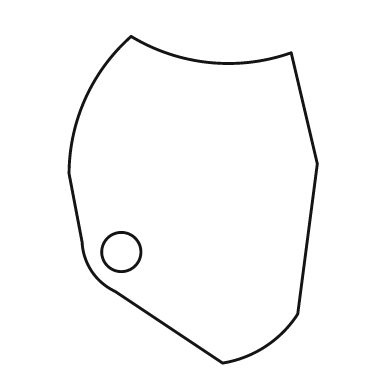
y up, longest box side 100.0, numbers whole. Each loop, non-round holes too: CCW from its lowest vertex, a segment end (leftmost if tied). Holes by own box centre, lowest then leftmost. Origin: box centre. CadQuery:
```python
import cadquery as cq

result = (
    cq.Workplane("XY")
    .moveTo(9.0, -50.0)
    .threePointArc((22.0, -45.0), (32.0, -35.0))
    .lineTo(38.0, 11.0)
    .lineTo(30.0, 45.0)
    .threePointArc((5.0, 42.0), (-19.0, 50.0))
    .threePointArc((-33.0, 31.0), (-38.0, 8.0))
    .lineTo(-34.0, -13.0)
    .threePointArc((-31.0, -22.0), (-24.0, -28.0))
    .close()
    .moveTo(-22.0, -16.0)
    .circle(6.0)
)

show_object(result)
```